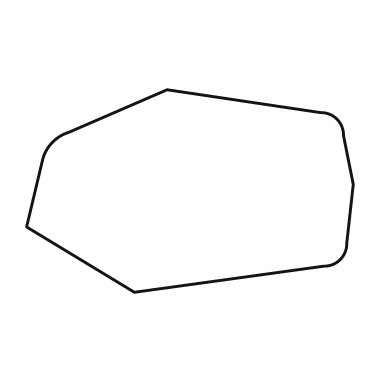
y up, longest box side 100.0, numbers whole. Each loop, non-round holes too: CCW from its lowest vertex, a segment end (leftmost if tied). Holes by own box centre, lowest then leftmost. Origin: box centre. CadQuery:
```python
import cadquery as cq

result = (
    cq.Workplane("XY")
    .moveTo(-17.0, -31.0)
    .lineTo(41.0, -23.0)
    .threePointArc((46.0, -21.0), (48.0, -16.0))
    .lineTo(50.0, 2.0)
    .lineTo(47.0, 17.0)
    .threePointArc((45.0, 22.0), (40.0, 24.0))
    .lineTo(-7.0, 31.0)
    .lineTo(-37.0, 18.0)
    .threePointArc((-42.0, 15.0), (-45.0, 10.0))
    .lineTo(-50.0, -11.0)
    .close()
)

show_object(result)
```